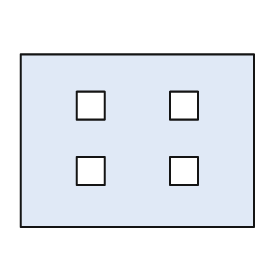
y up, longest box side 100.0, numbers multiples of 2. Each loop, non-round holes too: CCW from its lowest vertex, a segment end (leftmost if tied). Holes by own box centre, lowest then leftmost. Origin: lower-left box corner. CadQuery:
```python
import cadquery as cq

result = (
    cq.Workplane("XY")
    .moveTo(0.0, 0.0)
    .lineTo(100.0, 0.0)
    .lineTo(100.0, 74.0)
    .lineTo(0.0, 74.0)
    .close()
    .moveTo(24.0, 18.0)
    .lineTo(36.0, 18.0)
    .lineTo(36.0, 30.0)
    .lineTo(24.0, 30.0)
    .close()
    .moveTo(64.0, 18.0)
    .lineTo(76.0, 18.0)
    .lineTo(76.0, 30.0)
    .lineTo(64.0, 30.0)
    .close()
    .moveTo(24.0, 46.0)
    .lineTo(36.0, 46.0)
    .lineTo(36.0, 58.0)
    .lineTo(24.0, 58.0)
    .close()
    .moveTo(64.0, 46.0)
    .lineTo(76.0, 46.0)
    .lineTo(76.0, 58.0)
    .lineTo(64.0, 58.0)
    .close()
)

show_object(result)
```